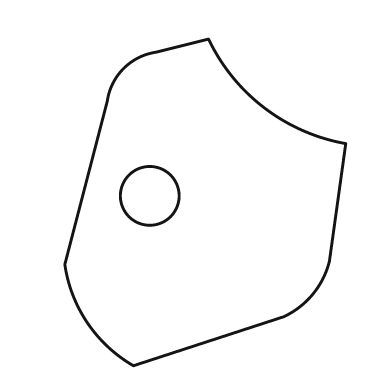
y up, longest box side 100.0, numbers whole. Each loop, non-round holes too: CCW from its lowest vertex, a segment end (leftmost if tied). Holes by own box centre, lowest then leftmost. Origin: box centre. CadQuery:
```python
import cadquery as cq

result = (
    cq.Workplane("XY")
    .moveTo(-22.0, -50.0)
    .lineTo(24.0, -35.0)
    .threePointArc((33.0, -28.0), (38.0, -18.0))
    .lineTo(43.0, 18.0)
    .threePointArc((18.0, 29.0), (1.0, 50.0))
    .lineTo(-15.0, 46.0)
    .threePointArc((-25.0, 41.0), (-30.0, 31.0))
    .lineTo(-43.0, -19.0)
    .threePointArc((-36.0, -37.0), (-22.0, -50.0))
    .close()
    .moveTo(-17.0, 2.0)
    .circle(9.0)
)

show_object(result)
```